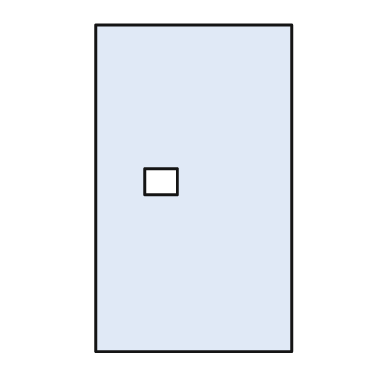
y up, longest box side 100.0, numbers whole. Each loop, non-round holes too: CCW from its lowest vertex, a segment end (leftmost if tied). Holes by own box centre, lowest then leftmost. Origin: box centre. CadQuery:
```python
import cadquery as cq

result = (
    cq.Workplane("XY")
    .moveTo(-30.0, -50.0)
    .lineTo(30.0, -50.0)
    .lineTo(30.0, 50.0)
    .lineTo(-30.0, 50.0)
    .close()
    .moveTo(-15.0, -2.0)
    .lineTo(-5.0, -2.0)
    .lineTo(-5.0, 6.0)
    .lineTo(-15.0, 6.0)
    .close()
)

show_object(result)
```